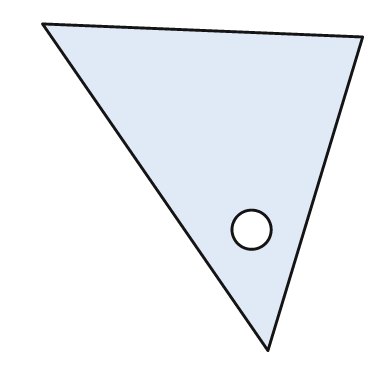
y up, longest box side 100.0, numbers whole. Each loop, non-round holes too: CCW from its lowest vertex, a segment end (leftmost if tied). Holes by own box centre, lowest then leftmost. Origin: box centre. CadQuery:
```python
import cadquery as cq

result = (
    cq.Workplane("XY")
    .moveTo(20.0, -50.0)
    .lineTo(49.0, 46.0)
    .lineTo(-49.0, 50.0)
    .close()
    .moveTo(15.0, -13.0)
    .circle(6.0)
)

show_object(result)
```